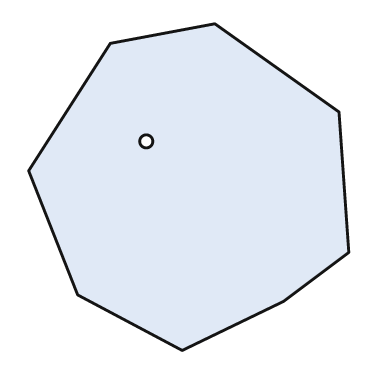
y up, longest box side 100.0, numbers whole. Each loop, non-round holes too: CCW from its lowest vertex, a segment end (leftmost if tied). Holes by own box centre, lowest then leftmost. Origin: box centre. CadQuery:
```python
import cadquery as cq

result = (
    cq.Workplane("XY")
    .moveTo(-2.0, -50.0)
    .lineTo(29.0, -35.0)
    .lineTo(49.0, -20.0)
    .lineTo(46.0, 23.0)
    .lineTo(8.0, 50.0)
    .lineTo(-24.0, 44.0)
    .lineTo(-49.0, 5.0)
    .lineTo(-34.0, -33.0)
    .close()
    .moveTo(-13.0, 14.0)
    .circle(2.0)
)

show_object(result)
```